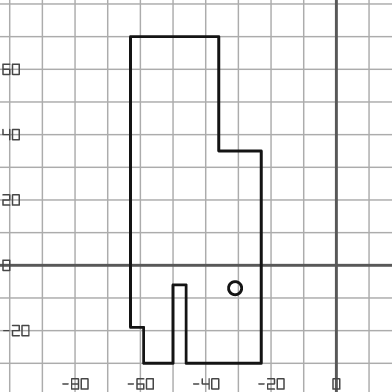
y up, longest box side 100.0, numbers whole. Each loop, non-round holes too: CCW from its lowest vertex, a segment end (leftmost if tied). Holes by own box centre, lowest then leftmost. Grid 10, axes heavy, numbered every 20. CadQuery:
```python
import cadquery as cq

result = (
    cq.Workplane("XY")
    .moveTo(-59.0, -30.0)
    .lineTo(-50.0, -30.0)
    .lineTo(-50.0, -6.0)
    .lineTo(-46.0, -6.0)
    .lineTo(-46.0, -30.0)
    .lineTo(-23.0, -30.0)
    .lineTo(-23.0, 35.0)
    .lineTo(-36.0, 35.0)
    .lineTo(-36.0, 70.0)
    .lineTo(-63.0, 70.0)
    .lineTo(-63.0, -19.0)
    .lineTo(-59.0, -19.0)
    .close()
    .moveTo(-31.0, -7.0)
    .circle(2.0)
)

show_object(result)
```